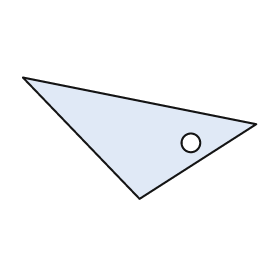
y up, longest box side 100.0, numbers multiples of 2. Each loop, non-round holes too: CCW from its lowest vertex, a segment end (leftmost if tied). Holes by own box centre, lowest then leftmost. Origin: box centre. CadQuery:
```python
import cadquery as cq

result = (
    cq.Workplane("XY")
    .moveTo(0.0, -26.0)
    .lineTo(50.0, 6.0)
    .lineTo(-50.0, 26.0)
    .close()
    .moveTo(22.0, -2.0)
    .circle(4.0)
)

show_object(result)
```